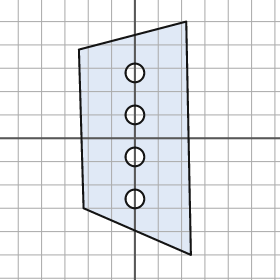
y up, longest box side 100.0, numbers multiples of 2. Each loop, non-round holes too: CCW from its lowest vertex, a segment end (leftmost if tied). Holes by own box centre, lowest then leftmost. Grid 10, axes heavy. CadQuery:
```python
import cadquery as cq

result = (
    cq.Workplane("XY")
    .moveTo(24.0, -50.0)
    .lineTo(22.0, 50.0)
    .lineTo(-24.0, 38.0)
    .lineTo(-22.0, -30.0)
    .close()
    .moveTo(0.0, -26.0)
    .circle(4.0)
    .moveTo(0.0, -8.0)
    .circle(4.0)
    .moveTo(0.0, 10.0)
    .circle(4.0)
    .moveTo(0.0, 28.0)
    .circle(4.0)
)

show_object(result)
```